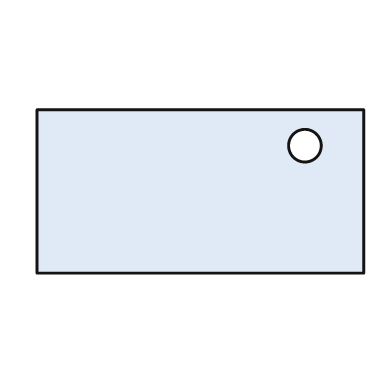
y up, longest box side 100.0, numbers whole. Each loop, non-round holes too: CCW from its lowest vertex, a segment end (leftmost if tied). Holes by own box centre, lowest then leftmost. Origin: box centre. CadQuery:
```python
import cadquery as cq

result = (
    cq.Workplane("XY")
    .moveTo(-50.0, -25.0)
    .lineTo(50.0, -25.0)
    .lineTo(50.0, 25.0)
    .lineTo(-50.0, 25.0)
    .close()
    .moveTo(32.0, 14.0)
    .circle(5.0)
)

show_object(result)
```